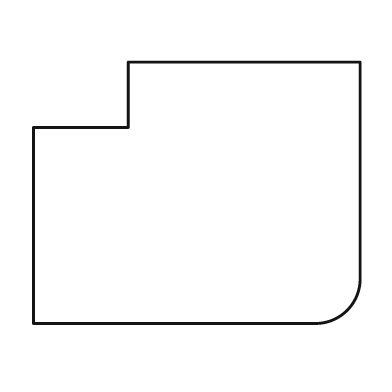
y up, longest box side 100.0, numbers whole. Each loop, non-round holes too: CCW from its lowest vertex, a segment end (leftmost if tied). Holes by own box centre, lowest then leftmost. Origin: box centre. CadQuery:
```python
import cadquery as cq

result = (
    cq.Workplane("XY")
    .moveTo(-50.0, -40.0)
    .lineTo(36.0, -40.0)
    .threePointArc((46.0, -36.0), (50.0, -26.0))
    .lineTo(50.0, 40.0)
    .lineTo(-21.0, 40.0)
    .lineTo(-21.0, 20.0)
    .lineTo(-50.0, 20.0)
    .close()
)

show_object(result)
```